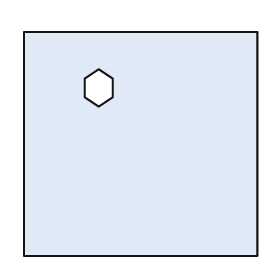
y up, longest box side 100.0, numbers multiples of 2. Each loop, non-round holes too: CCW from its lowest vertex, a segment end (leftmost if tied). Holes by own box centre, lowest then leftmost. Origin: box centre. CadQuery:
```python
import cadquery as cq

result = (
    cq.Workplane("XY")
    .moveTo(-50.0, -48.0)
    .lineTo(50.0, -48.0)
    .lineTo(50.0, 48.0)
    .lineTo(-50.0, 48.0)
    .close()
    .moveTo(-18.0, 16.0)
    .lineTo(-12.0, 20.0)
    .lineTo(-12.0, 28.0)
    .lineTo(-18.0, 32.0)
    .lineTo(-24.0, 28.0)
    .lineTo(-24.0, 20.0)
    .close()
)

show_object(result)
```